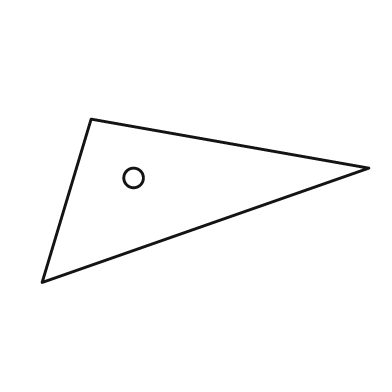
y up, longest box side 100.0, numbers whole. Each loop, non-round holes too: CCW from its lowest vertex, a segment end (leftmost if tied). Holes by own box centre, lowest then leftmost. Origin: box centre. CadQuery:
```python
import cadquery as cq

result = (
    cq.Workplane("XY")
    .moveTo(-50.0, -25.0)
    .lineTo(50.0, 10.0)
    .lineTo(-35.0, 25.0)
    .close()
    .moveTo(-22.0, 7.0)
    .circle(3.0)
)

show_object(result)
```